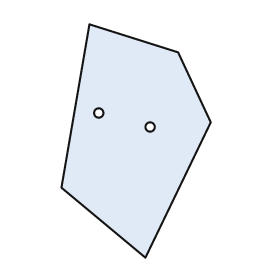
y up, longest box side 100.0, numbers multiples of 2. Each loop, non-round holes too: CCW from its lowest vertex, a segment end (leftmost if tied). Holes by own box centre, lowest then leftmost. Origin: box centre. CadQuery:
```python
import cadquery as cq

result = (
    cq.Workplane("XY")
    .moveTo(4.0, -50.0)
    .lineTo(32.0, 8.0)
    .lineTo(18.0, 38.0)
    .lineTo(-20.0, 50.0)
    .lineTo(-32.0, -20.0)
    .close()
    .moveTo(6.0, 6.0)
    .circle(2.0)
    .moveTo(-16.0, 12.0)
    .circle(2.0)
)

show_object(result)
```